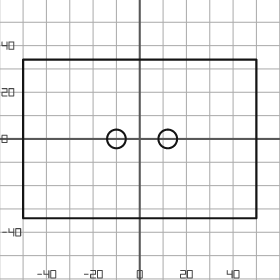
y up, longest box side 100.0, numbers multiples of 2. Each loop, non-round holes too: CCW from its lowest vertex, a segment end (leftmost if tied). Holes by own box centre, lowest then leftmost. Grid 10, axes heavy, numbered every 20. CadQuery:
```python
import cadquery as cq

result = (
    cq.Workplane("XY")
    .moveTo(-50.0, -34.0)
    .lineTo(50.0, -34.0)
    .lineTo(50.0, 34.0)
    .lineTo(-50.0, 34.0)
    .close()
    .moveTo(-10.0, 0.0)
    .circle(4.0)
    .moveTo(12.0, 0.0)
    .circle(4.0)
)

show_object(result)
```